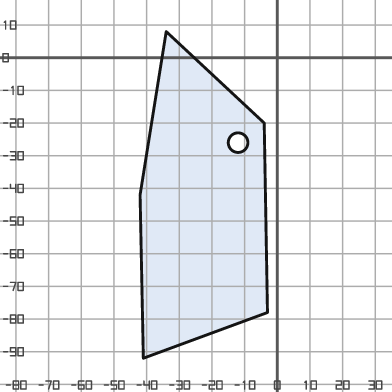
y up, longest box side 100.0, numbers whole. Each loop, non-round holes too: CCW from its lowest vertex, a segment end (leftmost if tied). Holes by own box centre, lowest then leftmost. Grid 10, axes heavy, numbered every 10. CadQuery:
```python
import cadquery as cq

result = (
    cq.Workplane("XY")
    .moveTo(-41.0, -92.0)
    .lineTo(-3.0, -78.0)
    .lineTo(-4.0, -20.0)
    .lineTo(-34.0, 8.0)
    .lineTo(-42.0, -42.0)
    .close()
    .moveTo(-12.0, -26.0)
    .circle(3.0)
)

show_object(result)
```